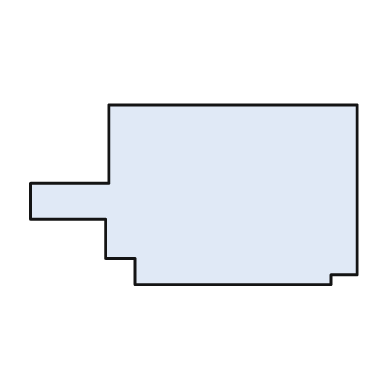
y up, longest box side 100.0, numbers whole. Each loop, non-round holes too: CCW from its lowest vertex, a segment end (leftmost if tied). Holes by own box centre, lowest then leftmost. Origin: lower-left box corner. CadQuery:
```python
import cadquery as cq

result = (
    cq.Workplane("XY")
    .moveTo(32.0, 0.0)
    .lineTo(92.0, 0.0)
    .lineTo(92.0, 3.0)
    .lineTo(100.0, 3.0)
    .lineTo(100.0, 55.0)
    .lineTo(24.0, 55.0)
    .lineTo(24.0, 31.0)
    .lineTo(0.0, 31.0)
    .lineTo(0.0, 20.0)
    .lineTo(23.0, 20.0)
    .lineTo(23.0, 8.0)
    .lineTo(32.0, 8.0)
    .close()
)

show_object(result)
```